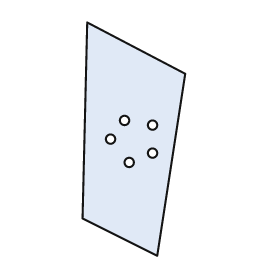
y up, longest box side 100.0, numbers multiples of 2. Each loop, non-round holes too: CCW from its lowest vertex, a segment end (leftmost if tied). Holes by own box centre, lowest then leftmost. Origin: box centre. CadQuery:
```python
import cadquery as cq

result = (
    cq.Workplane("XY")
    .moveTo(10.0, -50.0)
    .lineTo(22.0, 28.0)
    .lineTo(-20.0, 50.0)
    .lineTo(-22.0, -34.0)
    .close()
    .moveTo(-2.0, -10.0)
    .circle(2.0)
    .moveTo(8.0, -6.0)
    .circle(2.0)
    .moveTo(-10.0, 0.0)
    .circle(2.0)
    .moveTo(8.0, 6.0)
    .circle(2.0)
    .moveTo(-4.0, 8.0)
    .circle(2.0)
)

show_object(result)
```